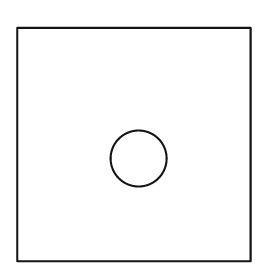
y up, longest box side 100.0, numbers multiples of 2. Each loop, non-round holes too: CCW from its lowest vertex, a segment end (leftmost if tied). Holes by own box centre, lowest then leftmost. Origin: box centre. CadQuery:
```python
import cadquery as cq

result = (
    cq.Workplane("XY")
    .moveTo(-50.0, -50.0)
    .lineTo(50.0, -50.0)
    .lineTo(50.0, 50.0)
    .lineTo(-50.0, 50.0)
    .close()
    .moveTo(2.0, -6.0)
    .circle(12.0)
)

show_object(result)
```